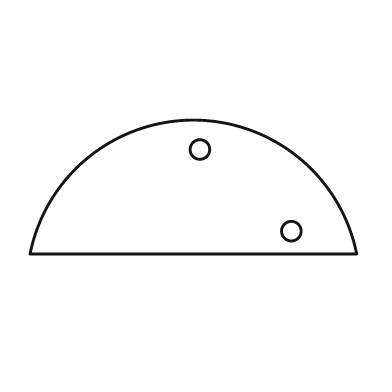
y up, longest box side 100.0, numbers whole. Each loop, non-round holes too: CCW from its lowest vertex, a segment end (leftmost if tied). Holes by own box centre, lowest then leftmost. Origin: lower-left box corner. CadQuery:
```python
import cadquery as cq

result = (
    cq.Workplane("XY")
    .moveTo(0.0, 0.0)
    .lineTo(100.0, 0.0)
    .threePointArc((50.0, 41.0), (0.0, 0.0))
    .close()
    .moveTo(80.0, 7.0)
    .circle(3.0)
    .moveTo(52.0, 32.0)
    .circle(3.0)
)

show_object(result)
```